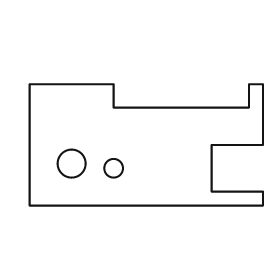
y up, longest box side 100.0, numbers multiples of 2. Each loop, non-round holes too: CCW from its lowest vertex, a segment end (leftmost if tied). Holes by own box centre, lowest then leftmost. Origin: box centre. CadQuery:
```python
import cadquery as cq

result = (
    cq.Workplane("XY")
    .moveTo(-50.0, -26.0)
    .lineTo(50.0, -26.0)
    .lineTo(50.0, -20.0)
    .lineTo(28.0, -20.0)
    .lineTo(28.0, 0.0)
    .lineTo(50.0, 0.0)
    .lineTo(50.0, 26.0)
    .lineTo(44.0, 26.0)
    .lineTo(44.0, 16.0)
    .lineTo(-14.0, 16.0)
    .lineTo(-14.0, 26.0)
    .lineTo(-50.0, 26.0)
    .close()
    .moveTo(-14.0, -10.0)
    .circle(4.0)
    .moveTo(-32.0, -8.0)
    .circle(6.0)
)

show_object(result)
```